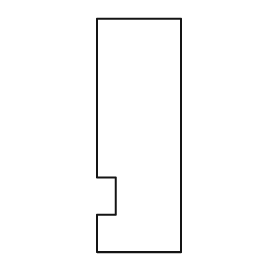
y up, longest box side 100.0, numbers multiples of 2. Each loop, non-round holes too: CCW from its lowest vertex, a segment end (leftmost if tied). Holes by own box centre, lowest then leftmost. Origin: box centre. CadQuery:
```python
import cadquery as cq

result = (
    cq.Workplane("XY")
    .moveTo(-18.0, -50.0)
    .lineTo(18.0, -50.0)
    .lineTo(18.0, 50.0)
    .lineTo(-18.0, 50.0)
    .lineTo(-18.0, -18.0)
    .lineTo(-10.0, -18.0)
    .lineTo(-10.0, -34.0)
    .lineTo(-18.0, -34.0)
    .close()
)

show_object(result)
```